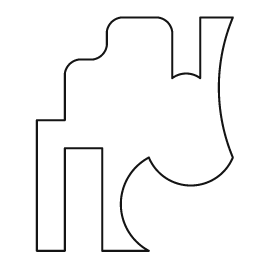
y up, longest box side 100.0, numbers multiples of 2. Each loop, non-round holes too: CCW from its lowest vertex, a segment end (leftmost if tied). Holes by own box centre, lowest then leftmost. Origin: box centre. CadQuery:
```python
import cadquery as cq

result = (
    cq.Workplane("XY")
    .moveTo(-42.0, -50.0)
    .lineTo(-30.0, -50.0)
    .lineTo(-30.0, -6.0)
    .lineTo(-14.0, -6.0)
    .lineTo(-14.0, -50.0)
    .lineTo(6.0, -50.0)
    .threePointArc((-6.0, -30.0), (6.0, -10.0))
    .threePointArc((24.0, -22.0), (42.0, -10.0))
    .threePointArc((36.0, 20.0), (42.0, 50.0))
    .lineTo(28.0, 50.0)
    .lineTo(28.0, 24.0)
    .threePointArc((22.0, 26.0), (16.0, 24.0))
    .lineTo(16.0, 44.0)
    .threePointArc((14.0, 48.0), (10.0, 50.0))
    .lineTo(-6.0, 50.0)
    .threePointArc((-10.0, 48.0), (-12.0, 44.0))
    .lineTo(-12.0, 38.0)
    .threePointArc((-14.0, 34.0), (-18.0, 32.0))
    .lineTo(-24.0, 32.0)
    .threePointArc((-28.0, 30.0), (-30.0, 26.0))
    .lineTo(-30.0, 6.0)
    .lineTo(-42.0, 6.0)
    .close()
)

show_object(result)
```